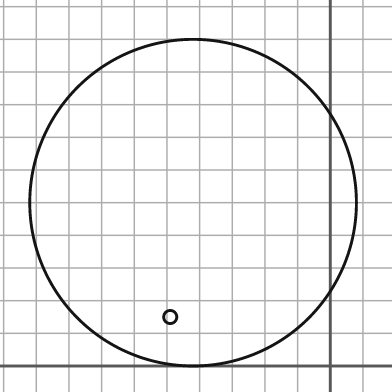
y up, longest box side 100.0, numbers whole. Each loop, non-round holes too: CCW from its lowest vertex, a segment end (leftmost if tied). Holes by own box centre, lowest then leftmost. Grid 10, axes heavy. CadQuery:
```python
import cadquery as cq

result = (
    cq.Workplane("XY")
    .moveTo(-42.0, 50.0)
    .circle(50.0)
    .moveTo(-49.0, 15.0)
    .circle(2.0)
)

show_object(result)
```